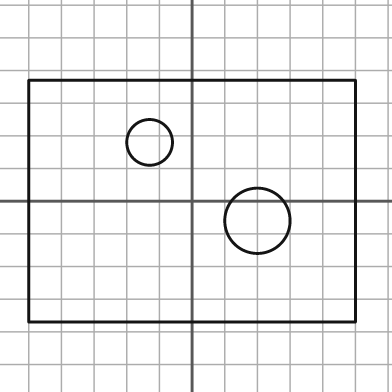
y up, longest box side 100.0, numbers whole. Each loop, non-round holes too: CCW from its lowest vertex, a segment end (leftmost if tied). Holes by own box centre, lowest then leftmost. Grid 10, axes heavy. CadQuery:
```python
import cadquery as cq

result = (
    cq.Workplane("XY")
    .moveTo(-50.0, -37.0)
    .lineTo(50.0, -37.0)
    .lineTo(50.0, 37.0)
    .lineTo(-50.0, 37.0)
    .close()
    .moveTo(20.0, -6.0)
    .circle(10.0)
    .moveTo(-13.0, 18.0)
    .circle(7.0)
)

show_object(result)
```